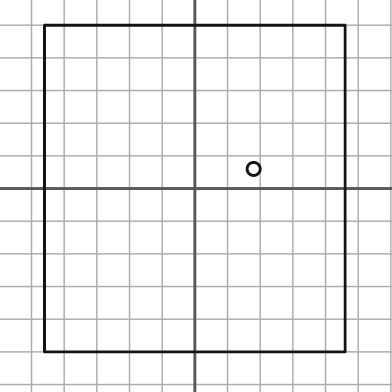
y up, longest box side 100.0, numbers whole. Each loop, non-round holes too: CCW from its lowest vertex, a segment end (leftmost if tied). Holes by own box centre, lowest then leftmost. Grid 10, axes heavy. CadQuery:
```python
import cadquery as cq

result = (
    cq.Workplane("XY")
    .moveTo(-46.0, -50.0)
    .lineTo(46.0, -50.0)
    .lineTo(46.0, 50.0)
    .lineTo(-46.0, 50.0)
    .close()
    .moveTo(18.0, 6.0)
    .circle(2.0)
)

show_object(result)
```